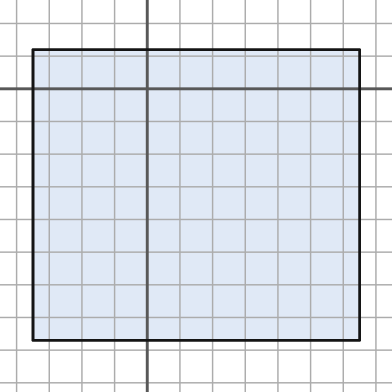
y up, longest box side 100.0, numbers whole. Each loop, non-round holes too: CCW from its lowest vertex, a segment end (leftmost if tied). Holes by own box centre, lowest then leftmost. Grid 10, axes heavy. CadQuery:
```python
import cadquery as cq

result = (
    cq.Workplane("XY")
    .moveTo(-35.0, -77.0)
    .lineTo(65.0, -77.0)
    .lineTo(65.0, 12.0)
    .lineTo(-35.0, 12.0)
    .close()
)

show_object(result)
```